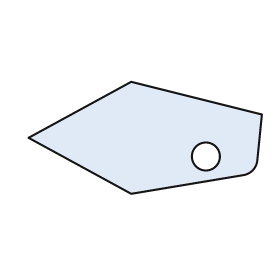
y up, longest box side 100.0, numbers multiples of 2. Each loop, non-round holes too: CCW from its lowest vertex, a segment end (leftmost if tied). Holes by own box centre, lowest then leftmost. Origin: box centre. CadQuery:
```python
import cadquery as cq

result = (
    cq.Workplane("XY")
    .moveTo(-6.0, -24.0)
    .lineTo(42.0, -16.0)
    .threePointArc((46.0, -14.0), (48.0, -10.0))
    .lineTo(50.0, 10.0)
    .lineTo(-6.0, 24.0)
    .lineTo(-50.0, 0.0)
    .close()
    .moveTo(26.0, -8.0)
    .circle(6.0)
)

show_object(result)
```